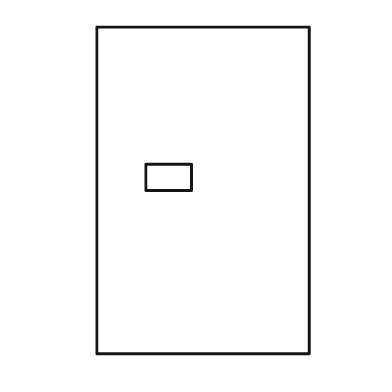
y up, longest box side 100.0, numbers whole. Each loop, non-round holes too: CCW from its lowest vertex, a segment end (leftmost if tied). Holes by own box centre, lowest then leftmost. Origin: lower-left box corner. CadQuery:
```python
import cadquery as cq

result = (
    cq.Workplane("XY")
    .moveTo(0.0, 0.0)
    .lineTo(65.0, 0.0)
    .lineTo(65.0, 100.0)
    .lineTo(0.0, 100.0)
    .close()
    .moveTo(15.0, 50.0)
    .lineTo(29.0, 50.0)
    .lineTo(29.0, 58.0)
    .lineTo(15.0, 58.0)
    .close()
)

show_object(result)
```